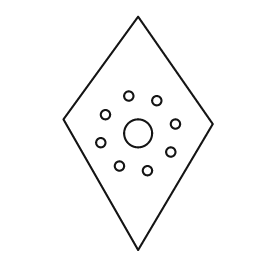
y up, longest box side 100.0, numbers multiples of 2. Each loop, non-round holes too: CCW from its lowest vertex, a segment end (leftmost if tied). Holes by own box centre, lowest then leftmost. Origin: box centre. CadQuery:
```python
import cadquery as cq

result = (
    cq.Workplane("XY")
    .moveTo(0.0, -50.0)
    .lineTo(32.0, 4.0)
    .lineTo(0.0, 50.0)
    .lineTo(-32.0, 6.0)
    .close()
    .moveTo(4.0, -16.0)
    .circle(2.0)
    .moveTo(-8.0, -14.0)
    .circle(2.0)
    .moveTo(14.0, -8.0)
    .circle(2.0)
    .moveTo(-16.0, -4.0)
    .circle(2.0)
    .moveTo(0.0, 0.0)
    .circle(6.0)
    .moveTo(16.0, 4.0)
    .circle(2.0)
    .moveTo(-14.0, 8.0)
    .circle(2.0)
    .moveTo(8.0, 14.0)
    .circle(2.0)
    .moveTo(-4.0, 16.0)
    .circle(2.0)
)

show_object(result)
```